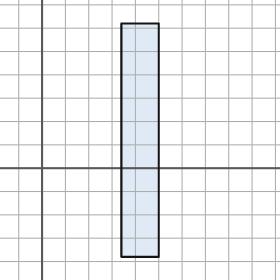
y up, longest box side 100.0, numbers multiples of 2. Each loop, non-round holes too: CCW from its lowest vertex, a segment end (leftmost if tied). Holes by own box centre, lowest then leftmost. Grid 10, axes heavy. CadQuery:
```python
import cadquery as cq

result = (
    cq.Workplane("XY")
    .moveTo(34.0, -38.0)
    .lineTo(50.0, -38.0)
    .lineTo(50.0, 62.0)
    .lineTo(34.0, 62.0)
    .close()
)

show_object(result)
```